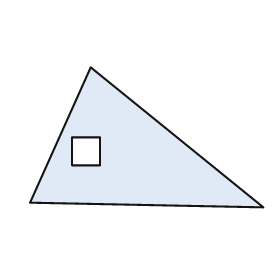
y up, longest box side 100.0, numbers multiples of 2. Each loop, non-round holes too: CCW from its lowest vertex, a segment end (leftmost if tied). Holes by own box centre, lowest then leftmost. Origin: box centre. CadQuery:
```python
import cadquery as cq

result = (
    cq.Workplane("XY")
    .moveTo(50.0, -30.0)
    .lineTo(-24.0, 30.0)
    .lineTo(-50.0, -28.0)
    .close()
    .moveTo(-32.0, -12.0)
    .lineTo(-20.0, -12.0)
    .lineTo(-20.0, 0.0)
    .lineTo(-32.0, 0.0)
    .close()
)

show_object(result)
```